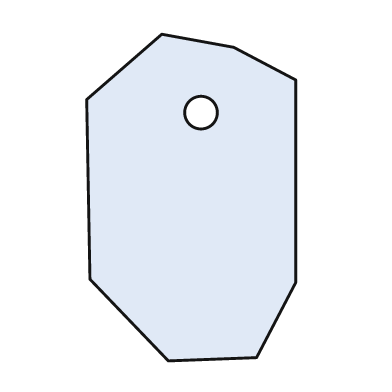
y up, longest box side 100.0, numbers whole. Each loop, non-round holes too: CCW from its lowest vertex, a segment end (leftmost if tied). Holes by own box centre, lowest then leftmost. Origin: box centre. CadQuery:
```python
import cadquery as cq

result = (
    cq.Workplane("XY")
    .moveTo(-7.0, -50.0)
    .lineTo(20.0, -49.0)
    .lineTo(32.0, -26.0)
    .lineTo(32.0, 36.0)
    .lineTo(13.0, 46.0)
    .lineTo(-9.0, 50.0)
    .lineTo(-32.0, 30.0)
    .lineTo(-31.0, -25.0)
    .close()
    .moveTo(3.0, 26.0)
    .circle(5.0)
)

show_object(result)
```